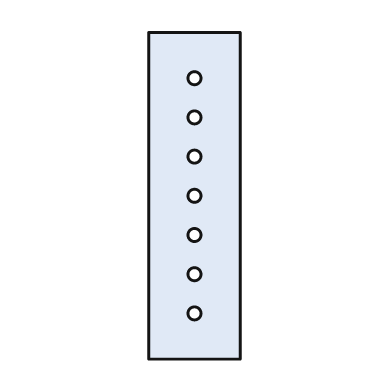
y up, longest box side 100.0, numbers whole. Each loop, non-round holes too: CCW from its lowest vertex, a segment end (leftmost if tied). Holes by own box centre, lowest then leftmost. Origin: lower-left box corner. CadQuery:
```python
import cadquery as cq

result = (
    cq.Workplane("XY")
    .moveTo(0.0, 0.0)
    .lineTo(28.0, 0.0)
    .lineTo(28.0, 100.0)
    .lineTo(0.0, 100.0)
    .close()
    .moveTo(14.0, 14.0)
    .circle(2.0)
    .moveTo(14.0, 26.0)
    .circle(2.0)
    .moveTo(14.0, 38.0)
    .circle(2.0)
    .moveTo(14.0, 50.0)
    .circle(2.0)
    .moveTo(14.0, 62.0)
    .circle(2.0)
    .moveTo(14.0, 74.0)
    .circle(2.0)
    .moveTo(14.0, 86.0)
    .circle(2.0)
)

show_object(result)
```